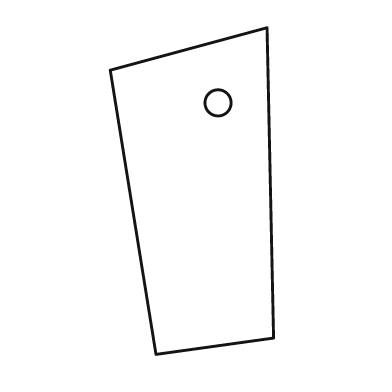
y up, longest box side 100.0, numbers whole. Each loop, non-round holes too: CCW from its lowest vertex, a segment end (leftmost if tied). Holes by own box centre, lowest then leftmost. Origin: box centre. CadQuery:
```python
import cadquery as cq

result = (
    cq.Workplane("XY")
    .moveTo(-11.0, -50.0)
    .lineTo(25.0, -45.0)
    .lineTo(23.0, 50.0)
    .lineTo(-25.0, 37.0)
    .close()
    .moveTo(8.0, 27.0)
    .circle(4.0)
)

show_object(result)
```